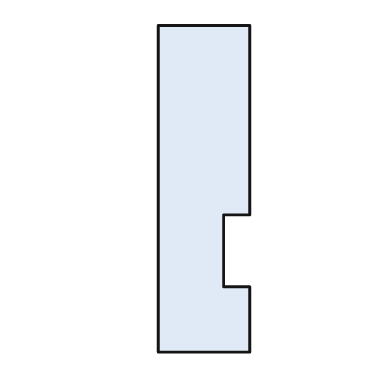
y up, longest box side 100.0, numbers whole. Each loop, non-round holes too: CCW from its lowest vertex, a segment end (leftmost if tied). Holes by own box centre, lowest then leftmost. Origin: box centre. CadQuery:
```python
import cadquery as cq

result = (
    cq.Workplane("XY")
    .moveTo(-14.0, -50.0)
    .lineTo(14.0, -50.0)
    .lineTo(14.0, -30.0)
    .lineTo(6.0, -30.0)
    .lineTo(6.0, -8.0)
    .lineTo(14.0, -8.0)
    .lineTo(14.0, 50.0)
    .lineTo(-14.0, 50.0)
    .close()
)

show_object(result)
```